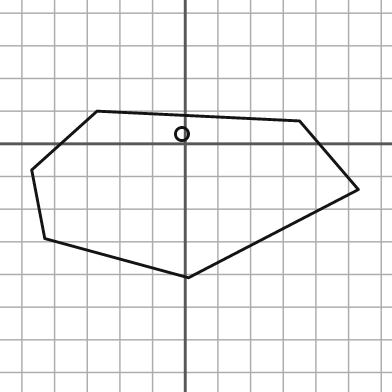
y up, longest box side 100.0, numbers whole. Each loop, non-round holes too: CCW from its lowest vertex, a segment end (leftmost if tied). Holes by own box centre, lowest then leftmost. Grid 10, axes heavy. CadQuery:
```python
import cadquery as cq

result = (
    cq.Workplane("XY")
    .moveTo(1.0, -41.0)
    .lineTo(53.0, -14.0)
    .lineTo(35.0, 7.0)
    .lineTo(-27.0, 10.0)
    .lineTo(-47.0, -8.0)
    .lineTo(-43.0, -29.0)
    .close()
    .moveTo(-1.0, 3.0)
    .circle(2.0)
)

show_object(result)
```